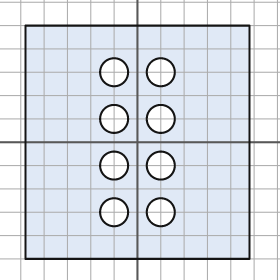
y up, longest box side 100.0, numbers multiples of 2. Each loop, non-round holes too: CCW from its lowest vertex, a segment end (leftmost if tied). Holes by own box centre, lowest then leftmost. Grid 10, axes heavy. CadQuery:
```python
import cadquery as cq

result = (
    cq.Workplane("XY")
    .moveTo(-48.0, -50.0)
    .lineTo(48.0, -50.0)
    .lineTo(48.0, 50.0)
    .lineTo(-48.0, 50.0)
    .close()
    .moveTo(-10.0, -30.0)
    .circle(6.0)
    .moveTo(10.0, -30.0)
    .circle(6.0)
    .moveTo(-10.0, -10.0)
    .circle(6.0)
    .moveTo(10.0, -10.0)
    .circle(6.0)
    .moveTo(-10.0, 10.0)
    .circle(6.0)
    .moveTo(10.0, 10.0)
    .circle(6.0)
    .moveTo(-10.0, 30.0)
    .circle(6.0)
    .moveTo(10.0, 30.0)
    .circle(6.0)
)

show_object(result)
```